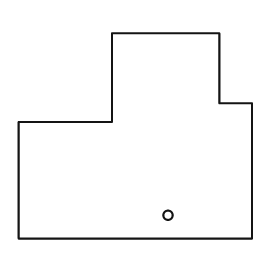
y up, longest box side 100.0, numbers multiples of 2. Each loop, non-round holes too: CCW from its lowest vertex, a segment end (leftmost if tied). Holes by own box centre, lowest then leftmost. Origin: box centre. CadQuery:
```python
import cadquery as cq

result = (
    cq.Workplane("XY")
    .moveTo(-50.0, -44.0)
    .lineTo(50.0, -44.0)
    .lineTo(50.0, 14.0)
    .lineTo(36.0, 14.0)
    .lineTo(36.0, 44.0)
    .lineTo(-10.0, 44.0)
    .lineTo(-10.0, 6.0)
    .lineTo(-50.0, 6.0)
    .close()
    .moveTo(14.0, -34.0)
    .circle(2.0)
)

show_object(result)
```